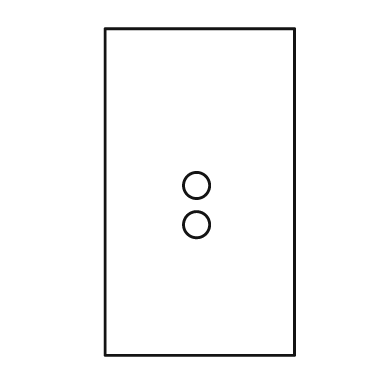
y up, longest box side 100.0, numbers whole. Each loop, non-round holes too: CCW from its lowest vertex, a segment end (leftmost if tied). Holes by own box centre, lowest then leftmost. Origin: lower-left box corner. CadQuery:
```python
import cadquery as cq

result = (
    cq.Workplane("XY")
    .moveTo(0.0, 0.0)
    .lineTo(58.0, 0.0)
    .lineTo(58.0, 100.0)
    .lineTo(0.0, 100.0)
    .close()
    .moveTo(28.0, 40.0)
    .circle(4.0)
    .moveTo(28.0, 52.0)
    .circle(4.0)
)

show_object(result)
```